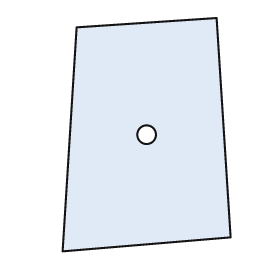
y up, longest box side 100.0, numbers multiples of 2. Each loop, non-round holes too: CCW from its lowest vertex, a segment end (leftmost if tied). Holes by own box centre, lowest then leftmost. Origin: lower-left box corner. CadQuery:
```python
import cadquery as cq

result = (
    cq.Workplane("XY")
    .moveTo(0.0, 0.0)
    .lineTo(72.0, 6.0)
    .lineTo(66.0, 100.0)
    .lineTo(6.0, 96.0)
    .close()
    .moveTo(36.0, 50.0)
    .circle(4.0)
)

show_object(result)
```